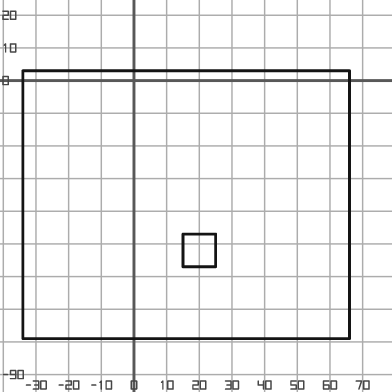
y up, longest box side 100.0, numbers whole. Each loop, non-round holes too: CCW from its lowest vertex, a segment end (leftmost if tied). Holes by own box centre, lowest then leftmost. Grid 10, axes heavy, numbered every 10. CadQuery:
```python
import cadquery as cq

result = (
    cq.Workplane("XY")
    .moveTo(-34.0, -79.0)
    .lineTo(66.0, -79.0)
    .lineTo(66.0, 3.0)
    .lineTo(-34.0, 3.0)
    .close()
    .moveTo(15.0, -57.0)
    .lineTo(25.0, -57.0)
    .lineTo(25.0, -47.0)
    .lineTo(15.0, -47.0)
    .close()
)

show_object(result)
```